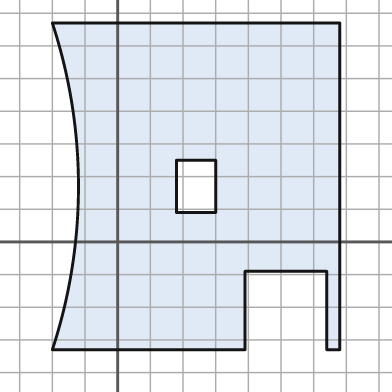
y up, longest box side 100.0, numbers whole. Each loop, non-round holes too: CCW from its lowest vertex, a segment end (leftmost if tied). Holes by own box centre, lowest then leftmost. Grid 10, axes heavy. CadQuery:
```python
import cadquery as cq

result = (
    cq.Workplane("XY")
    .moveTo(-20.0, -33.0)
    .lineTo(39.0, -33.0)
    .lineTo(39.0, -9.0)
    .lineTo(64.0, -9.0)
    .lineTo(64.0, -33.0)
    .lineTo(68.0, -33.0)
    .lineTo(68.0, 67.0)
    .lineTo(-20.0, 67.0)
    .threePointArc((-12.0, 17.0), (-20.0, -33.0))
    .close()
    .moveTo(18.0, 9.0)
    .lineTo(30.0, 9.0)
    .lineTo(30.0, 25.0)
    .lineTo(18.0, 25.0)
    .close()
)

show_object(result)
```